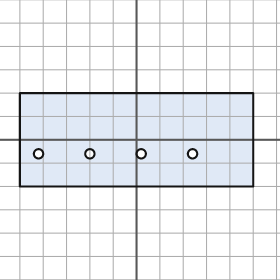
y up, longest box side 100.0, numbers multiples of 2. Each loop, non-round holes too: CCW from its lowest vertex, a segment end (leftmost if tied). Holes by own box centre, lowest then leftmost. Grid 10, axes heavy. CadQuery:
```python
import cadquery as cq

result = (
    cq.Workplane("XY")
    .moveTo(-50.0, -20.0)
    .lineTo(50.0, -20.0)
    .lineTo(50.0, 20.0)
    .lineTo(-50.0, 20.0)
    .close()
    .moveTo(-42.0, -6.0)
    .circle(2.0)
    .moveTo(-20.0, -6.0)
    .circle(2.0)
    .moveTo(2.0, -6.0)
    .circle(2.0)
    .moveTo(24.0, -6.0)
    .circle(2.0)
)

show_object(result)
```